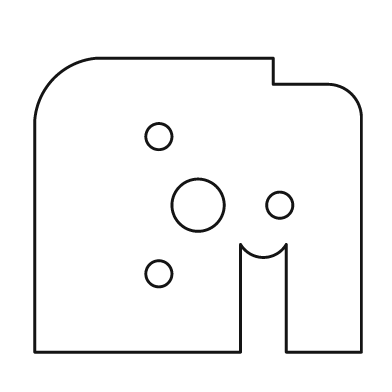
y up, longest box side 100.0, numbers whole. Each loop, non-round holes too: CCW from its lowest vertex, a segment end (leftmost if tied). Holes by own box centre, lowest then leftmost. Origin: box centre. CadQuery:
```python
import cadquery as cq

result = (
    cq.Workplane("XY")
    .moveTo(-50.0, -45.0)
    .lineTo(13.0, -45.0)
    .lineTo(13.0, -12.0)
    .threePointArc((20.0, -16.0), (27.0, -12.0))
    .lineTo(27.0, -45.0)
    .lineTo(50.0, -45.0)
    .lineTo(50.0, 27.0)
    .threePointArc((47.0, 34.0), (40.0, 37.0))
    .lineTo(23.0, 37.0)
    .lineTo(23.0, 45.0)
    .lineTo(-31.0, 45.0)
    .threePointArc((-44.0, 39.0), (-50.0, 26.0))
    .close()
    .moveTo(-12.0, -21.0)
    .circle(4.0)
    .moveTo(0.0, 0.0)
    .circle(8.0)
    .moveTo(25.0, 0.0)
    .circle(4.0)
    .moveTo(-12.0, 21.0)
    .circle(4.0)
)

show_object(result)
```